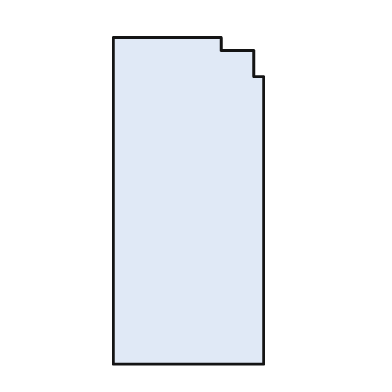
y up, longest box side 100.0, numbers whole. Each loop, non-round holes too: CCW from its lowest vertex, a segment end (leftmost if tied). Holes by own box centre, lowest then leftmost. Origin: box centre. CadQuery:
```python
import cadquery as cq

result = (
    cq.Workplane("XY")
    .moveTo(-23.0, -50.0)
    .lineTo(23.0, -50.0)
    .lineTo(23.0, 38.0)
    .lineTo(20.0, 38.0)
    .lineTo(20.0, 46.0)
    .lineTo(10.0, 46.0)
    .lineTo(10.0, 50.0)
    .lineTo(-23.0, 50.0)
    .close()
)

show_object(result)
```